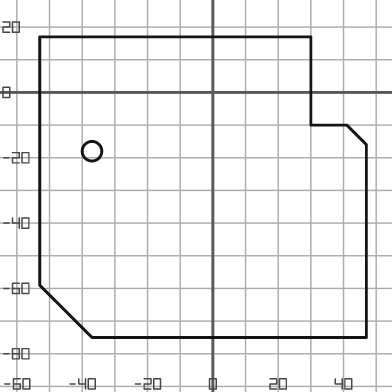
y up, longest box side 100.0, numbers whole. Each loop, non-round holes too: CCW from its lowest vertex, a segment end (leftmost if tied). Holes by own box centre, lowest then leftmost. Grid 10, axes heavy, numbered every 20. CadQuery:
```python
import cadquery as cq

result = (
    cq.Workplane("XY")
    .moveTo(-37.0, -75.0)
    .lineTo(47.0, -75.0)
    .lineTo(47.0, -16.0)
    .lineTo(41.0, -10.0)
    .lineTo(30.0, -10.0)
    .lineTo(30.0, 17.0)
    .lineTo(-53.0, 17.0)
    .lineTo(-53.0, -59.0)
    .close()
    .moveTo(-37.0, -18.0)
    .circle(3.0)
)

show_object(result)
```